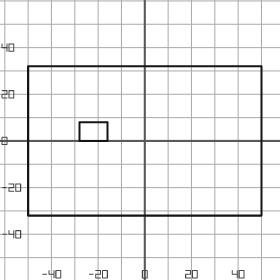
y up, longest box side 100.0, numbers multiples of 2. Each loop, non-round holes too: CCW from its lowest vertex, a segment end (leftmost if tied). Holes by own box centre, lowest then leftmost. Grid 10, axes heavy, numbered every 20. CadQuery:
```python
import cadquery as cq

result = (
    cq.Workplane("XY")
    .moveTo(-50.0, -32.0)
    .lineTo(50.0, -32.0)
    .lineTo(50.0, 32.0)
    .lineTo(-50.0, 32.0)
    .close()
    .moveTo(-28.0, 0.0)
    .lineTo(-16.0, 0.0)
    .lineTo(-16.0, 8.0)
    .lineTo(-28.0, 8.0)
    .close()
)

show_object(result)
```